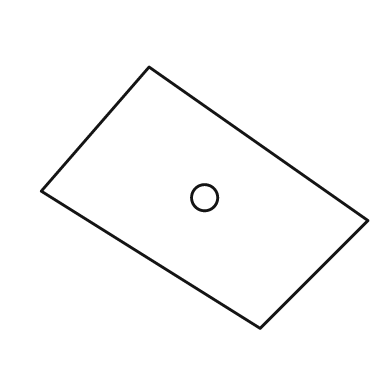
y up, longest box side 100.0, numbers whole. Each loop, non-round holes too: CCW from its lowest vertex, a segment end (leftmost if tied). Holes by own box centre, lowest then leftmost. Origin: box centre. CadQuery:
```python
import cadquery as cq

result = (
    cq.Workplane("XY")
    .moveTo(17.0, -40.0)
    .lineTo(50.0, -7.0)
    .lineTo(-17.0, 40.0)
    .lineTo(-50.0, 2.0)
    .close()
    .moveTo(0.0, 0.0)
    .circle(4.0)
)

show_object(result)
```